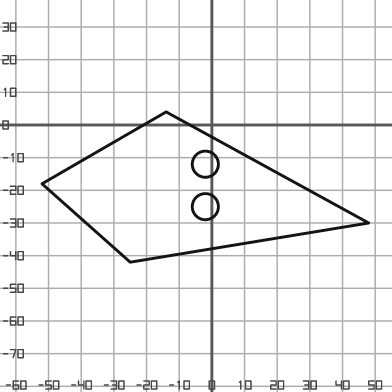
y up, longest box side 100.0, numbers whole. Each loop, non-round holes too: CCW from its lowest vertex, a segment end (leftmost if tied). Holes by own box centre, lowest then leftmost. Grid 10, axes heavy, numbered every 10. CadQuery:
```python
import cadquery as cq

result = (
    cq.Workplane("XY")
    .moveTo(-25.0, -42.0)
    .lineTo(48.0, -30.0)
    .lineTo(-14.0, 4.0)
    .lineTo(-52.0, -18.0)
    .close()
    .moveTo(-2.0, -25.0)
    .circle(4.0)
    .moveTo(-2.0, -12.0)
    .circle(4.0)
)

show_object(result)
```